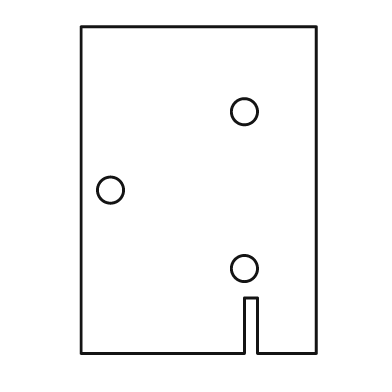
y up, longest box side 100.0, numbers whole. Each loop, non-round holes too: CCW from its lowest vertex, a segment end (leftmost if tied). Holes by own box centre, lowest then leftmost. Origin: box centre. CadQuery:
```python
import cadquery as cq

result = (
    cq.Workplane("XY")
    .moveTo(-36.0, -50.0)
    .lineTo(14.0, -50.0)
    .lineTo(14.0, -33.0)
    .lineTo(18.0, -33.0)
    .lineTo(18.0, -50.0)
    .lineTo(36.0, -50.0)
    .lineTo(36.0, 50.0)
    .lineTo(-36.0, 50.0)
    .close()
    .moveTo(14.0, -24.0)
    .circle(4.0)
    .moveTo(-27.0, 0.0)
    .circle(4.0)
    .moveTo(14.0, 24.0)
    .circle(4.0)
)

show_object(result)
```